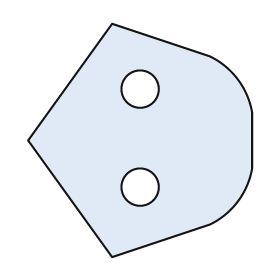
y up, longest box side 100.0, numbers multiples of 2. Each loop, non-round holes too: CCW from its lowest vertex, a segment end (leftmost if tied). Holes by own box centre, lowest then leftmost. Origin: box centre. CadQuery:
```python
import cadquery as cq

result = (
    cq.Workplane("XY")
    .moveTo(-12.0, -50.0)
    .lineTo(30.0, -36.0)
    .threePointArc((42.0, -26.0), (48.0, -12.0))
    .lineTo(48.0, 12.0)
    .threePointArc((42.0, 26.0), (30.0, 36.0))
    .lineTo(-12.0, 50.0)
    .lineTo(-48.0, 0.0)
    .close()
    .moveTo(0.0, -20.0)
    .circle(8.0)
    .moveTo(0.0, 22.0)
    .circle(8.0)
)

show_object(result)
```